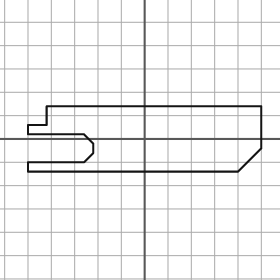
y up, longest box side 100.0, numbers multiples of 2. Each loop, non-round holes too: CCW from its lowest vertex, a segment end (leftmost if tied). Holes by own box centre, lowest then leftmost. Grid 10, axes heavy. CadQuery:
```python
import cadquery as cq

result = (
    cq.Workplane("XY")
    .moveTo(-50.0, -14.0)
    .lineTo(40.0, -14.0)
    .lineTo(50.0, -4.0)
    .lineTo(50.0, 14.0)
    .lineTo(-42.0, 14.0)
    .lineTo(-42.0, 6.0)
    .lineTo(-50.0, 6.0)
    .lineTo(-50.0, 2.0)
    .lineTo(-26.0, 2.0)
    .lineTo(-22.0, -2.0)
    .lineTo(-22.0, -6.0)
    .lineTo(-26.0, -10.0)
    .lineTo(-50.0, -10.0)
    .close()
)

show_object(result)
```